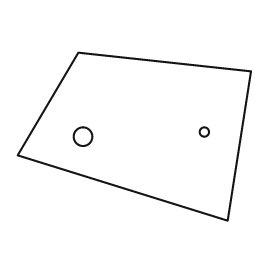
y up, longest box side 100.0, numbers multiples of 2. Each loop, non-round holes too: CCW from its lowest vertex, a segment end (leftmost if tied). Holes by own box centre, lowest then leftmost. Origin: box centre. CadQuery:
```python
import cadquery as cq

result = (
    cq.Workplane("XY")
    .moveTo(40.0, -36.0)
    .lineTo(50.0, 28.0)
    .lineTo(-24.0, 36.0)
    .lineTo(-50.0, -8.0)
    .close()
    .moveTo(-22.0, 0.0)
    .circle(4.0)
    .moveTo(30.0, 2.0)
    .circle(2.0)
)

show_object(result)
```